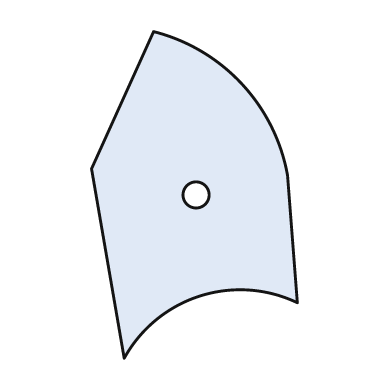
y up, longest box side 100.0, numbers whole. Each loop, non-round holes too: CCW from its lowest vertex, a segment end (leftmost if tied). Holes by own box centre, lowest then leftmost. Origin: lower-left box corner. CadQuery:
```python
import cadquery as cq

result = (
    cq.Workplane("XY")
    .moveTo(10.0, 0.0)
    .threePointArc((33.0, 19.0), (63.0, 17.0))
    .lineTo(60.0, 56.0)
    .threePointArc((46.0, 84.0), (19.0, 100.0))
    .lineTo(0.0, 58.0)
    .close()
    .moveTo(32.0, 50.0)
    .circle(4.0)
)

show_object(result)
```